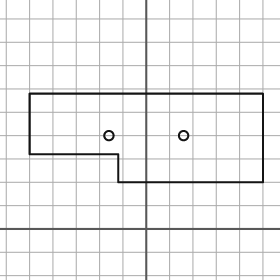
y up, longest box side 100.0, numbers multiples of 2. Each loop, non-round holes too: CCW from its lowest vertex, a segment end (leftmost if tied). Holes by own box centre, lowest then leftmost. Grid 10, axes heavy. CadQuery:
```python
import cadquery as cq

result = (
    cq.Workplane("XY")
    .moveTo(-12.0, 20.0)
    .lineTo(50.0, 20.0)
    .lineTo(50.0, 58.0)
    .lineTo(-50.0, 58.0)
    .lineTo(-50.0, 32.0)
    .lineTo(-12.0, 32.0)
    .close()
    .moveTo(-16.0, 40.0)
    .circle(2.0)
    .moveTo(16.0, 40.0)
    .circle(2.0)
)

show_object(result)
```